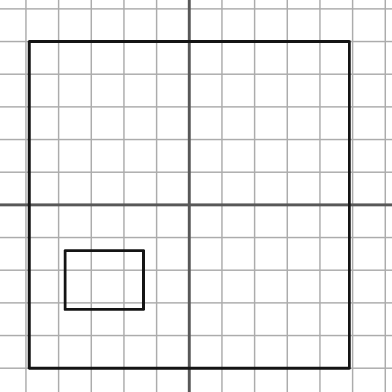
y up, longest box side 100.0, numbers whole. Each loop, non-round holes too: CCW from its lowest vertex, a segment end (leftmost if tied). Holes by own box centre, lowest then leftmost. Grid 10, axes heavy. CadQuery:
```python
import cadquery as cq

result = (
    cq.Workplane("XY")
    .moveTo(-49.0, -50.0)
    .lineTo(49.0, -50.0)
    .lineTo(49.0, 50.0)
    .lineTo(-49.0, 50.0)
    .close()
    .moveTo(-38.0, -32.0)
    .lineTo(-14.0, -32.0)
    .lineTo(-14.0, -14.0)
    .lineTo(-38.0, -14.0)
    .close()
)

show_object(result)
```